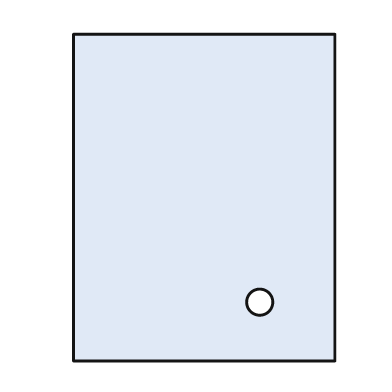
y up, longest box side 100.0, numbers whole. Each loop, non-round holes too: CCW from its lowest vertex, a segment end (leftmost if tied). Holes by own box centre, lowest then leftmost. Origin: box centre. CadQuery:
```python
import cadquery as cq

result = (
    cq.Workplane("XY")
    .moveTo(-40.0, -50.0)
    .lineTo(40.0, -50.0)
    .lineTo(40.0, 50.0)
    .lineTo(-40.0, 50.0)
    .close()
    .moveTo(17.0, -32.0)
    .circle(4.0)
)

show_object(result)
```